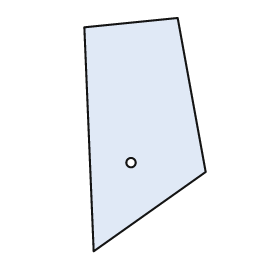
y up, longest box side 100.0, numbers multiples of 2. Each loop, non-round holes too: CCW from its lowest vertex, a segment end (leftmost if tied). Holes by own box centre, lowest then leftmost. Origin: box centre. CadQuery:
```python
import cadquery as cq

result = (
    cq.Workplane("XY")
    .moveTo(-22.0, -50.0)
    .lineTo(26.0, -16.0)
    .lineTo(14.0, 50.0)
    .lineTo(-26.0, 46.0)
    .close()
    .moveTo(-6.0, -12.0)
    .circle(2.0)
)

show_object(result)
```